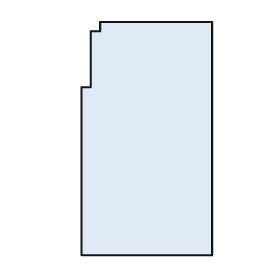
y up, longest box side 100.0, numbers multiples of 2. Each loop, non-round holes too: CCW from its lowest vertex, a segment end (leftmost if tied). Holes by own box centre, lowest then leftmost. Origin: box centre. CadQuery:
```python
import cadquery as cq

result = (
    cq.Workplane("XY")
    .moveTo(-28.0, -50.0)
    .lineTo(28.0, -50.0)
    .lineTo(28.0, 50.0)
    .lineTo(-20.0, 50.0)
    .lineTo(-20.0, 46.0)
    .lineTo(-24.0, 46.0)
    .lineTo(-24.0, 22.0)
    .lineTo(-28.0, 22.0)
    .close()
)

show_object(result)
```